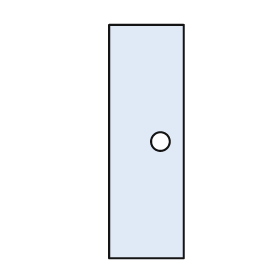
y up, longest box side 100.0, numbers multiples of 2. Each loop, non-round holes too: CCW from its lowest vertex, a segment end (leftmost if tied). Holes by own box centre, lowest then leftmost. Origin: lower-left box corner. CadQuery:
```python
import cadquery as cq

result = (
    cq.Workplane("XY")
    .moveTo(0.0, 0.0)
    .lineTo(32.0, 0.0)
    .lineTo(32.0, 100.0)
    .lineTo(0.0, 100.0)
    .close()
    .moveTo(22.0, 50.0)
    .circle(4.0)
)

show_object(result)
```